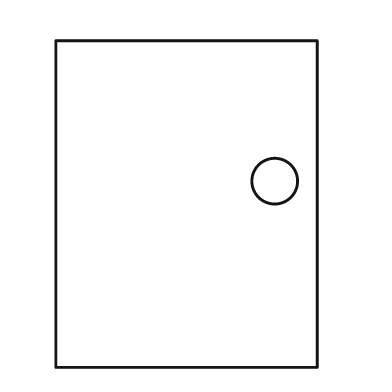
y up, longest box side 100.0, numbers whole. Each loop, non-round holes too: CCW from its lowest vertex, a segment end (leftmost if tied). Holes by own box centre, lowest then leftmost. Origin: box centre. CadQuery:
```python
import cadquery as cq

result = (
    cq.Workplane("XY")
    .moveTo(-40.0, -50.0)
    .lineTo(40.0, -50.0)
    .lineTo(40.0, 50.0)
    .lineTo(-40.0, 50.0)
    .close()
    .moveTo(27.0, 7.0)
    .circle(7.0)
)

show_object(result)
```